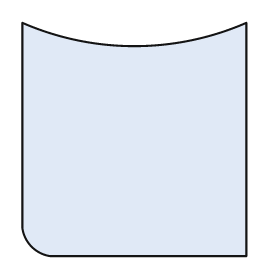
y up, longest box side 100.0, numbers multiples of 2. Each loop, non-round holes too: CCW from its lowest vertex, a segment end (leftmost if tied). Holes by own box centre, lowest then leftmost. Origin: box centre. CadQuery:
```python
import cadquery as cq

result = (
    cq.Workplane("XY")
    .moveTo(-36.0, -50.0)
    .lineTo(48.0, -50.0)
    .lineTo(48.0, 50.0)
    .threePointArc((0.0, 40.0), (-48.0, 50.0))
    .lineTo(-48.0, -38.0)
    .threePointArc((-44.0, -46.0), (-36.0, -50.0))
    .close()
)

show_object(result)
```